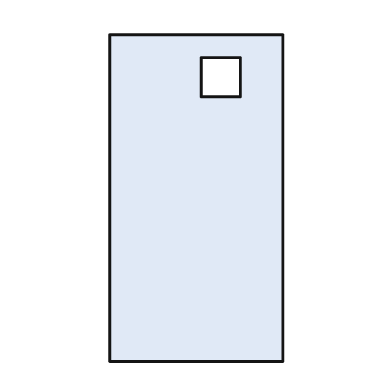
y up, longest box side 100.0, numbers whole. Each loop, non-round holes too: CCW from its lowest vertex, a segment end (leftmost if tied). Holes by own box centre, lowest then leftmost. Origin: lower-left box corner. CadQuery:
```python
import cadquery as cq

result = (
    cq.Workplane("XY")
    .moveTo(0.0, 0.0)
    .lineTo(53.0, 0.0)
    .lineTo(53.0, 100.0)
    .lineTo(0.0, 100.0)
    .close()
    .moveTo(28.0, 81.0)
    .lineTo(40.0, 81.0)
    .lineTo(40.0, 93.0)
    .lineTo(28.0, 93.0)
    .close()
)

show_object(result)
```